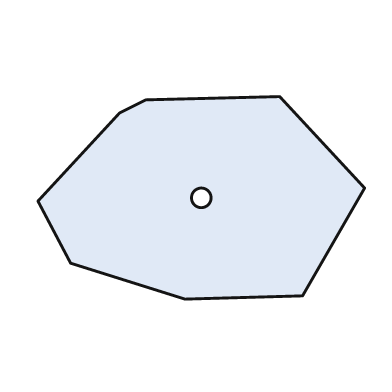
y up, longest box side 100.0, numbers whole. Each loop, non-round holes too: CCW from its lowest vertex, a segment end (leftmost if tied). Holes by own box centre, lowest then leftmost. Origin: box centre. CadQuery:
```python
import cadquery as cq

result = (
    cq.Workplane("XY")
    .moveTo(-5.0, -31.0)
    .lineTo(31.0, -30.0)
    .lineTo(50.0, 3.0)
    .lineTo(24.0, 31.0)
    .lineTo(-17.0, 30.0)
    .lineTo(-25.0, 26.0)
    .lineTo(-50.0, -1.0)
    .lineTo(-40.0, -20.0)
    .close()
    .moveTo(0.0, 0.0)
    .circle(3.0)
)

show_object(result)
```